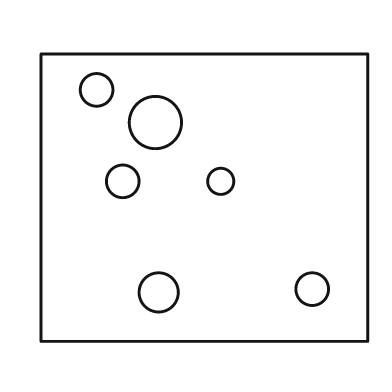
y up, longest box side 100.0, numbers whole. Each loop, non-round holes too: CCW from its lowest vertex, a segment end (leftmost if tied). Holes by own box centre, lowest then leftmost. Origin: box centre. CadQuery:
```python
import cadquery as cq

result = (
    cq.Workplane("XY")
    .moveTo(-50.0, -44.0)
    .lineTo(50.0, -44.0)
    .lineTo(50.0, 44.0)
    .lineTo(-50.0, 44.0)
    .close()
    .moveTo(-14.0, -29.0)
    .circle(6.0)
    .moveTo(33.0, -28.0)
    .circle(5.0)
    .moveTo(-25.0, 5.0)
    .circle(5.0)
    .moveTo(5.0, 5.0)
    .circle(4.0)
    .moveTo(-15.0, 23.0)
    .circle(8.0)
    .moveTo(-33.0, 33.0)
    .circle(5.0)
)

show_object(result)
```